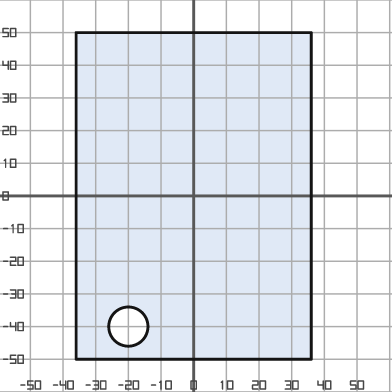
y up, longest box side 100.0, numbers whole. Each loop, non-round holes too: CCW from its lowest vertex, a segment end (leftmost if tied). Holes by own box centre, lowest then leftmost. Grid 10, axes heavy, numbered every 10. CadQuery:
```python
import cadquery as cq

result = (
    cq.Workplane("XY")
    .moveTo(-36.0, -50.0)
    .lineTo(36.0, -50.0)
    .lineTo(36.0, 50.0)
    .lineTo(-36.0, 50.0)
    .close()
    .moveTo(-20.0, -40.0)
    .circle(6.0)
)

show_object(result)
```